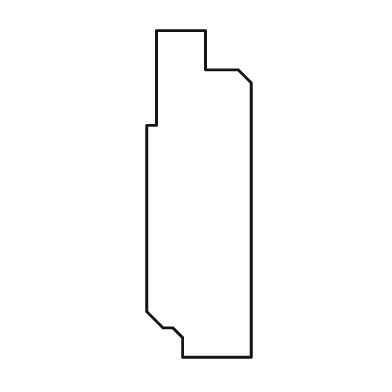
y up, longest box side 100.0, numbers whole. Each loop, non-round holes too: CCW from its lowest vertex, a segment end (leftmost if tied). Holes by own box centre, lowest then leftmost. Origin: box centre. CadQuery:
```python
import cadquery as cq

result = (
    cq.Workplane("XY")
    .moveTo(-5.0, -50.0)
    .lineTo(16.0, -50.0)
    .lineTo(16.0, 34.0)
    .lineTo(12.0, 38.0)
    .lineTo(2.0, 38.0)
    .lineTo(2.0, 50.0)
    .lineTo(-13.0, 50.0)
    .lineTo(-13.0, 21.0)
    .lineTo(-16.0, 21.0)
    .lineTo(-16.0, -36.0)
    .lineTo(-11.0, -41.0)
    .lineTo(-8.0, -41.0)
    .lineTo(-5.0, -44.0)
    .close()
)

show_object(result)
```